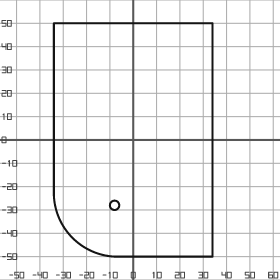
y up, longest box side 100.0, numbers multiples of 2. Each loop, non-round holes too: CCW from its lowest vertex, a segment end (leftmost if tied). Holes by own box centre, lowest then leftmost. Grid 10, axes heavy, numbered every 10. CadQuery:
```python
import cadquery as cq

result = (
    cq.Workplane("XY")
    .moveTo(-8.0, -50.0)
    .lineTo(34.0, -50.0)
    .lineTo(34.0, 50.0)
    .lineTo(-34.0, 50.0)
    .lineTo(-34.0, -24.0)
    .threePointArc((-26.0, -42.0), (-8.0, -50.0))
    .close()
    .moveTo(-8.0, -28.0)
    .circle(2.0)
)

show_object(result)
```